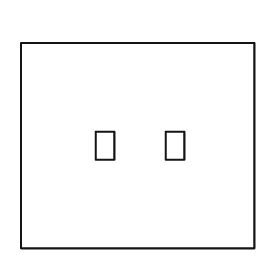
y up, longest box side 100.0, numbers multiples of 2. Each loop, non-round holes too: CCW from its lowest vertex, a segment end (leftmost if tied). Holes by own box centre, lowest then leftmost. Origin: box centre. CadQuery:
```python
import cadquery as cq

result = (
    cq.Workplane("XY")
    .moveTo(-50.0, -44.0)
    .lineTo(50.0, -44.0)
    .lineTo(50.0, 44.0)
    .lineTo(-50.0, 44.0)
    .close()
    .moveTo(-18.0, -6.0)
    .lineTo(-10.0, -6.0)
    .lineTo(-10.0, 6.0)
    .lineTo(-18.0, 6.0)
    .close()
    .moveTo(12.0, -6.0)
    .lineTo(20.0, -6.0)
    .lineTo(20.0, 6.0)
    .lineTo(12.0, 6.0)
    .close()
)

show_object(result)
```